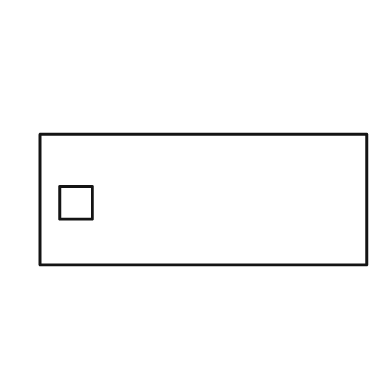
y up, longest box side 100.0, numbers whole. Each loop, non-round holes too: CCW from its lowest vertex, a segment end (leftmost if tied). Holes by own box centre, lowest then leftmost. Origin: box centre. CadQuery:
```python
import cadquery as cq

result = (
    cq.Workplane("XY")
    .moveTo(-50.0, -20.0)
    .lineTo(50.0, -20.0)
    .lineTo(50.0, 20.0)
    .lineTo(-50.0, 20.0)
    .close()
    .moveTo(-44.0, -6.0)
    .lineTo(-34.0, -6.0)
    .lineTo(-34.0, 4.0)
    .lineTo(-44.0, 4.0)
    .close()
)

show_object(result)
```